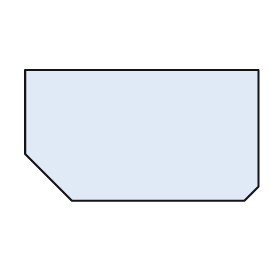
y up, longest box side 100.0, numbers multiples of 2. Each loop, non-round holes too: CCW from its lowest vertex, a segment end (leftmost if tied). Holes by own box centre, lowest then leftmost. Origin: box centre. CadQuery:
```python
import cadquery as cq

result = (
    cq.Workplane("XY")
    .moveTo(-30.0, -28.0)
    .lineTo(44.0, -28.0)
    .lineTo(50.0, -22.0)
    .lineTo(50.0, 28.0)
    .lineTo(-50.0, 28.0)
    .lineTo(-50.0, -8.0)
    .close()
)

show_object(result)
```